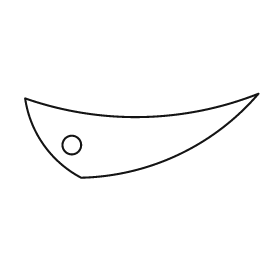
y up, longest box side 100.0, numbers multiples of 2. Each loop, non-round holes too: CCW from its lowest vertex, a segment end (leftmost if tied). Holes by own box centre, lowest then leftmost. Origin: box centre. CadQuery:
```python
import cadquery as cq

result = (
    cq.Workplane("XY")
    .moveTo(-26.0, -18.0)
    .threePointArc((16.0, -8.0), (50.0, 18.0))
    .threePointArc((0.0, 8.0), (-50.0, 16.0))
    .threePointArc((-42.0, -4.0), (-26.0, -18.0))
    .close()
    .moveTo(-30.0, -4.0)
    .circle(4.0)
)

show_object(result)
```